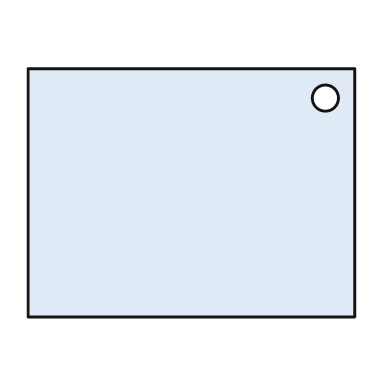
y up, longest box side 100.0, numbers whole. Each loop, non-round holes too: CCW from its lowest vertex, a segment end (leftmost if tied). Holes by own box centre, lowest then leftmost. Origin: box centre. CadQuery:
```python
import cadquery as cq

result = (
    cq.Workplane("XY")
    .moveTo(-50.0, -38.0)
    .lineTo(50.0, -38.0)
    .lineTo(50.0, 38.0)
    .lineTo(-50.0, 38.0)
    .close()
    .moveTo(41.0, 29.0)
    .circle(4.0)
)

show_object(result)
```